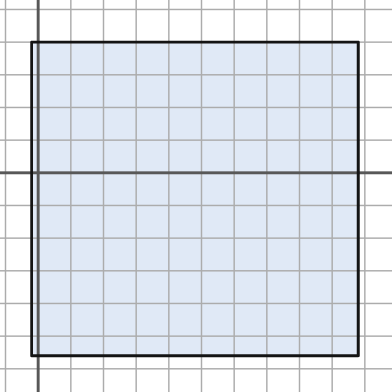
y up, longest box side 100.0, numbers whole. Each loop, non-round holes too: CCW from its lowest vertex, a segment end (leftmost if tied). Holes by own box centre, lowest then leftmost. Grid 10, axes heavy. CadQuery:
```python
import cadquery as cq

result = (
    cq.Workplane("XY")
    .moveTo(-2.0, -56.0)
    .lineTo(98.0, -56.0)
    .lineTo(98.0, 40.0)
    .lineTo(-2.0, 40.0)
    .close()
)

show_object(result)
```